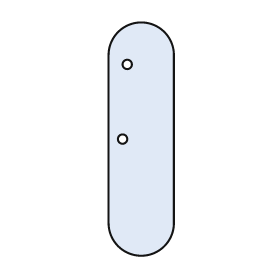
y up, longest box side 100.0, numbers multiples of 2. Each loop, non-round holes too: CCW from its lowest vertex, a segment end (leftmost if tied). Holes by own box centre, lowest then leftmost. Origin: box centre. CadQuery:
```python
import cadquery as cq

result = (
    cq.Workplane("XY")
    .moveTo(-14.0, -36.0)
    .threePointArc((0.0, -50.0), (14.0, -36.0))
    .lineTo(14.0, 36.0)
    .threePointArc((0.0, 50.0), (-14.0, 36.0))
    .close()
    .moveTo(-8.0, 0.0)
    .circle(2.0)
    .moveTo(-6.0, 32.0)
    .circle(2.0)
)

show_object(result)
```